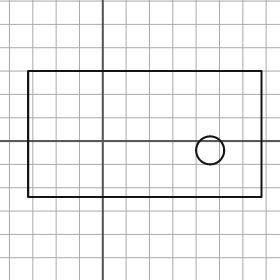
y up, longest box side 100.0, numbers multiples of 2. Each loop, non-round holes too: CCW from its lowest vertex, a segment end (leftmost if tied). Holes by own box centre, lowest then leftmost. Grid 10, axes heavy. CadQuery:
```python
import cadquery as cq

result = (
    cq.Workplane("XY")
    .moveTo(-32.0, -24.0)
    .lineTo(68.0, -24.0)
    .lineTo(68.0, 30.0)
    .lineTo(-32.0, 30.0)
    .close()
    .moveTo(46.0, -4.0)
    .circle(6.0)
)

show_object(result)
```